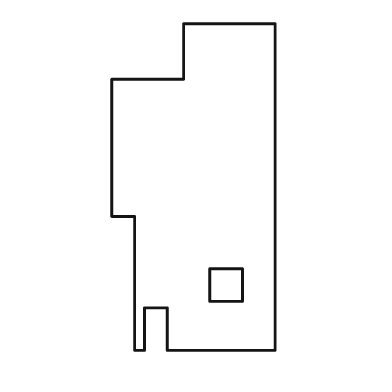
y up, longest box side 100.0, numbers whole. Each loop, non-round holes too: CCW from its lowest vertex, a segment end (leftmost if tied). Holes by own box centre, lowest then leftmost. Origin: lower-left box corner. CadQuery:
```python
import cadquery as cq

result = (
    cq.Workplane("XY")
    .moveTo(7.0, 0.0)
    .lineTo(10.0, 0.0)
    .lineTo(10.0, 13.0)
    .lineTo(17.0, 13.0)
    .lineTo(17.0, 0.0)
    .lineTo(50.0, 0.0)
    .lineTo(50.0, 100.0)
    .lineTo(22.0, 100.0)
    .lineTo(22.0, 83.0)
    .lineTo(0.0, 83.0)
    .lineTo(0.0, 41.0)
    .lineTo(7.0, 41.0)
    .close()
    .moveTo(30.0, 15.0)
    .lineTo(40.0, 15.0)
    .lineTo(40.0, 25.0)
    .lineTo(30.0, 25.0)
    .close()
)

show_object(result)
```